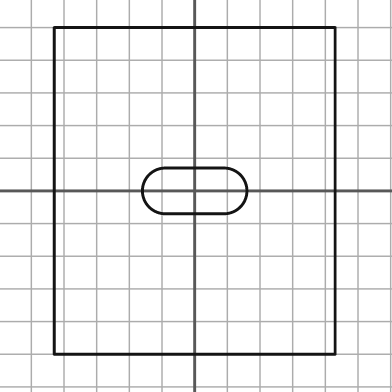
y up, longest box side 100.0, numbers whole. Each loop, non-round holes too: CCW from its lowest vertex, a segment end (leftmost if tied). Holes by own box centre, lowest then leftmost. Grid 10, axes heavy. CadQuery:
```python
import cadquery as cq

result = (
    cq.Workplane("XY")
    .moveTo(-43.0, -50.0)
    .lineTo(43.0, -50.0)
    .lineTo(43.0, 50.0)
    .lineTo(-43.0, 50.0)
    .close()
    .moveTo(-9.0, -7.0)
    .lineTo(9.0, -7.0)
    .threePointArc((16.0, 0.0), (9.0, 7.0))
    .lineTo(-9.0, 7.0)
    .threePointArc((-16.0, 0.0), (-9.0, -7.0))
    .close()
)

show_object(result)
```